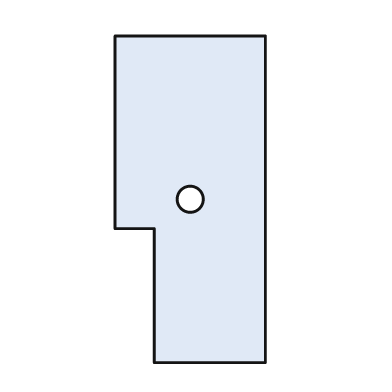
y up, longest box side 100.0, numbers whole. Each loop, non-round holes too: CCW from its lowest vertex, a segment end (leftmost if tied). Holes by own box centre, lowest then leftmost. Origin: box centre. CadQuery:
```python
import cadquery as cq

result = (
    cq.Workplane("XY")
    .moveTo(-11.0, -50.0)
    .lineTo(23.0, -50.0)
    .lineTo(23.0, 50.0)
    .lineTo(-23.0, 50.0)
    .lineTo(-23.0, -9.0)
    .lineTo(-11.0, -9.0)
    .close()
    .moveTo(0.0, 0.0)
    .circle(4.0)
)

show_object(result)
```